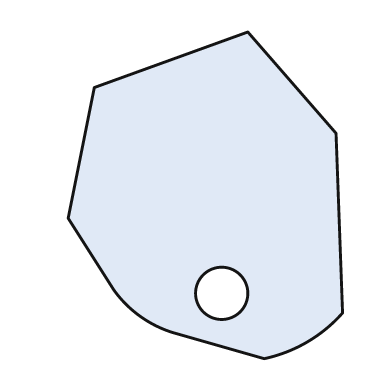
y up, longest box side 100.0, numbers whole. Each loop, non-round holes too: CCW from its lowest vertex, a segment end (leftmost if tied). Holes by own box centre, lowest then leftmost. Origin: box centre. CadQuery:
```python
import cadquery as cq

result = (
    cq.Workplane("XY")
    .moveTo(18.0, -50.0)
    .threePointArc((31.0, -45.0), (42.0, -36.0))
    .lineTo(40.0, 19.0)
    .lineTo(13.0, 50.0)
    .lineTo(-34.0, 33.0)
    .lineTo(-42.0, -7.0)
    .lineTo(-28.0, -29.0)
    .threePointArc((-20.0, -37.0), (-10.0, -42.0))
    .close()
    .moveTo(5.0, -30.0)
    .circle(8.0)
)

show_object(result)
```